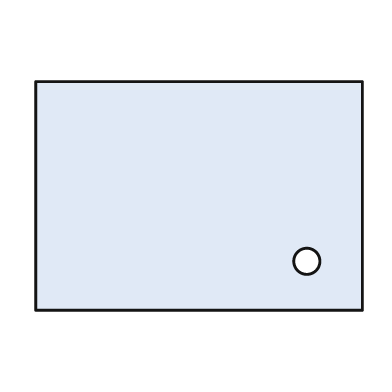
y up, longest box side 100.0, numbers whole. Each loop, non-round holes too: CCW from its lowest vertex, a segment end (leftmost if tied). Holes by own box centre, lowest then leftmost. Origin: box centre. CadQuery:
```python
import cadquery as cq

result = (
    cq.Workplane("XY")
    .moveTo(-50.0, -35.0)
    .lineTo(50.0, -35.0)
    .lineTo(50.0, 35.0)
    .lineTo(-50.0, 35.0)
    .close()
    .moveTo(33.0, -20.0)
    .circle(4.0)
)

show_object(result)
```